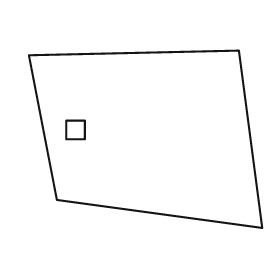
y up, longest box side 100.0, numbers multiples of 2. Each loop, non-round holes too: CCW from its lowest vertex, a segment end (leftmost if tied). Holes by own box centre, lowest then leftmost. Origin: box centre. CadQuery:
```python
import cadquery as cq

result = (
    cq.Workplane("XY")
    .moveTo(50.0, -38.0)
    .lineTo(40.0, 38.0)
    .lineTo(-50.0, 36.0)
    .lineTo(-38.0, -26.0)
    .close()
    .moveTo(-34.0, 0.0)
    .lineTo(-26.0, 0.0)
    .lineTo(-26.0, 8.0)
    .lineTo(-34.0, 8.0)
    .close()
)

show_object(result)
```